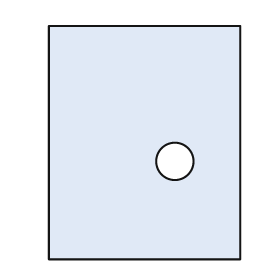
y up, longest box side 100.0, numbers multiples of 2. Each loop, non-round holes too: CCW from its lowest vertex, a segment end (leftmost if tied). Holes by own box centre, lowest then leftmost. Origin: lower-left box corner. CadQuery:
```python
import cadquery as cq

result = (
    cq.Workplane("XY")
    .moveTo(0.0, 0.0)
    .lineTo(82.0, 0.0)
    .lineTo(82.0, 100.0)
    .lineTo(0.0, 100.0)
    .close()
    .moveTo(54.0, 42.0)
    .circle(8.0)
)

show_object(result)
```